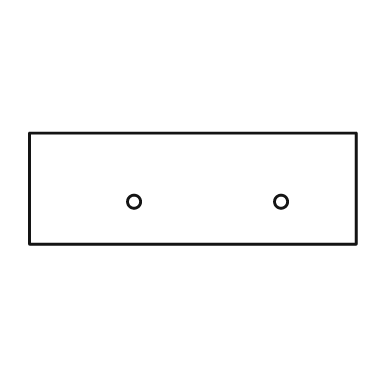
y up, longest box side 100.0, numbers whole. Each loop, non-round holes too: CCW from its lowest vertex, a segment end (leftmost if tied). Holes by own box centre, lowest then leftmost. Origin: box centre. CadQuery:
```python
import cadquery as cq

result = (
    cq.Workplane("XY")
    .moveTo(-50.0, -17.0)
    .lineTo(50.0, -17.0)
    .lineTo(50.0, 17.0)
    .lineTo(-50.0, 17.0)
    .close()
    .moveTo(-18.0, -4.0)
    .circle(2.0)
    .moveTo(27.0, -4.0)
    .circle(2.0)
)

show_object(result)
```